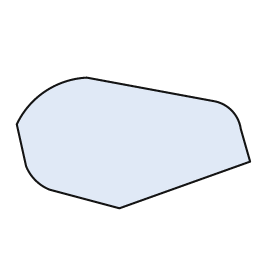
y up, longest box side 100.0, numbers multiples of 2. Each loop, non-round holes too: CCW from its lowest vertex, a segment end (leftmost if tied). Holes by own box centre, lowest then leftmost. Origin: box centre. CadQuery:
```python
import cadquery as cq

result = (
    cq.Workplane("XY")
    .moveTo(-6.0, -28.0)
    .lineTo(50.0, -8.0)
    .lineTo(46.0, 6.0)
    .threePointArc((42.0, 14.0), (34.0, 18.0))
    .lineTo(-20.0, 28.0)
    .threePointArc((-38.0, 22.0), (-50.0, 8.0))
    .lineTo(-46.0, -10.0)
    .threePointArc((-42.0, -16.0), (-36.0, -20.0))
    .close()
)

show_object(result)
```